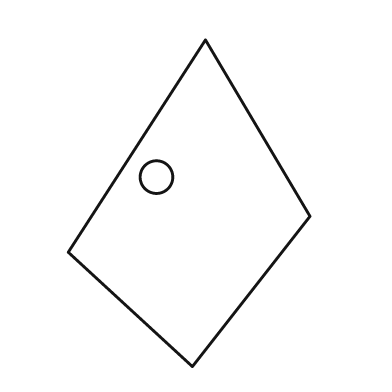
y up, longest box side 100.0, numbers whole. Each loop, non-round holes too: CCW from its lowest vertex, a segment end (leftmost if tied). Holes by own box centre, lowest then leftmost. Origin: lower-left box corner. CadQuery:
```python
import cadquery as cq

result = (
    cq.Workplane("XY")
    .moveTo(38.0, 0.0)
    .lineTo(74.0, 46.0)
    .lineTo(42.0, 100.0)
    .lineTo(0.0, 35.0)
    .close()
    .moveTo(27.0, 58.0)
    .circle(5.0)
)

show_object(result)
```